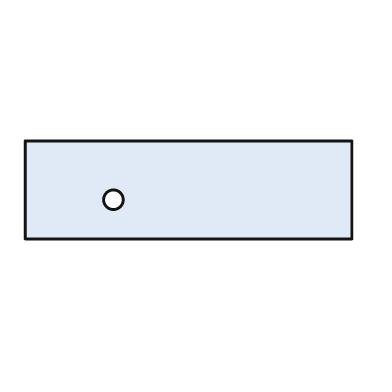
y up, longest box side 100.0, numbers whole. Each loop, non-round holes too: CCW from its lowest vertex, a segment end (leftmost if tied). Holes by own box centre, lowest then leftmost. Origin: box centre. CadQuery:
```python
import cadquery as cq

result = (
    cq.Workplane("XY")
    .moveTo(-50.0, -15.0)
    .lineTo(50.0, -15.0)
    .lineTo(50.0, 15.0)
    .lineTo(-50.0, 15.0)
    .close()
    .moveTo(-23.0, -3.0)
    .circle(3.0)
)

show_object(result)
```